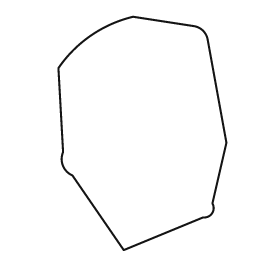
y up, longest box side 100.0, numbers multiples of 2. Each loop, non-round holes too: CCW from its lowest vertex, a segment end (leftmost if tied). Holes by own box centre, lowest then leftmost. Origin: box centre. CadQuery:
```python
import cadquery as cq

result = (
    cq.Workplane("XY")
    .moveTo(-8.0, -50.0)
    .lineTo(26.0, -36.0)
    .threePointArc((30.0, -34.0), (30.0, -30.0))
    .lineTo(36.0, -4.0)
    .lineTo(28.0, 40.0)
    .threePointArc((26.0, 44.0), (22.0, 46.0))
    .lineTo(-4.0, 50.0)
    .threePointArc((-22.0, 42.0), (-36.0, 28.0))
    .lineTo(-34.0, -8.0)
    .threePointArc((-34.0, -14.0), (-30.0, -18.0))
    .close()
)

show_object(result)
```